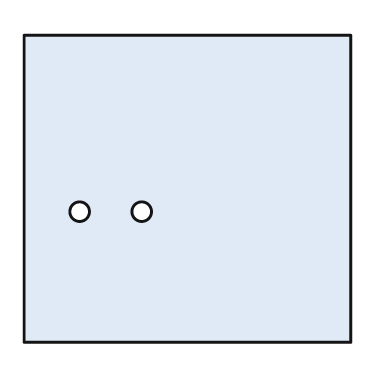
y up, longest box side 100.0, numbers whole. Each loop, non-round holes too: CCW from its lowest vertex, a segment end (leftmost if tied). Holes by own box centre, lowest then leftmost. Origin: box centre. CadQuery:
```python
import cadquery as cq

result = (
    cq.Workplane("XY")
    .moveTo(-50.0, -47.0)
    .lineTo(50.0, -47.0)
    .lineTo(50.0, 47.0)
    .lineTo(-50.0, 47.0)
    .close()
    .moveTo(-33.0, -7.0)
    .circle(3.0)
    .moveTo(-14.0, -7.0)
    .circle(3.0)
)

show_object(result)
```